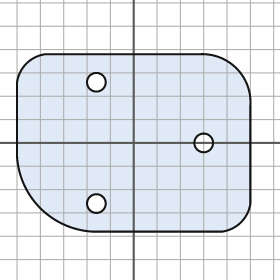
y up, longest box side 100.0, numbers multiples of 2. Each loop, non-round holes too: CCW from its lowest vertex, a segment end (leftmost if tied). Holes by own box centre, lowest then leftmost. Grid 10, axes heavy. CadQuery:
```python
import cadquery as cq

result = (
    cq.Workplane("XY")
    .moveTo(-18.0, -38.0)
    .lineTo(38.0, -38.0)
    .threePointArc((46.0, -34.0), (50.0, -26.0))
    .lineTo(50.0, 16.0)
    .threePointArc((44.0, 32.0), (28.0, 38.0))
    .lineTo(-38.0, 38.0)
    .threePointArc((-46.0, 34.0), (-50.0, 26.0))
    .lineTo(-50.0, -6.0)
    .threePointArc((-40.0, -28.0), (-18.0, -38.0))
    .close()
    .moveTo(-16.0, -26.0)
    .circle(4.0)
    .moveTo(30.0, 0.0)
    .circle(4.0)
    .moveTo(-16.0, 26.0)
    .circle(4.0)
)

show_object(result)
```